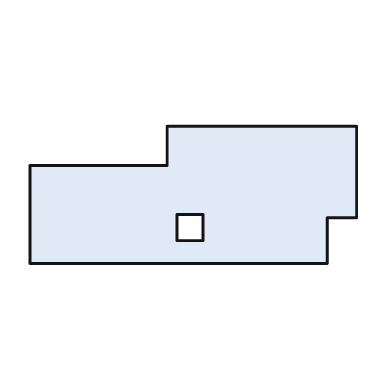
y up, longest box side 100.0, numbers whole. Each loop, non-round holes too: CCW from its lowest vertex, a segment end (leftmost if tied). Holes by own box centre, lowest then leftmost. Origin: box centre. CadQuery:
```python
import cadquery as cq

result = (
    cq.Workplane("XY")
    .moveTo(-50.0, -21.0)
    .lineTo(41.0, -21.0)
    .lineTo(41.0, -7.0)
    .lineTo(50.0, -7.0)
    .lineTo(50.0, 21.0)
    .lineTo(-8.0, 21.0)
    .lineTo(-8.0, 9.0)
    .lineTo(-50.0, 9.0)
    .close()
    .moveTo(-5.0, -14.0)
    .lineTo(3.0, -14.0)
    .lineTo(3.0, -6.0)
    .lineTo(-5.0, -6.0)
    .close()
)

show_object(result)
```